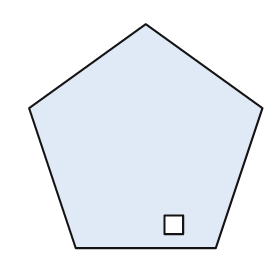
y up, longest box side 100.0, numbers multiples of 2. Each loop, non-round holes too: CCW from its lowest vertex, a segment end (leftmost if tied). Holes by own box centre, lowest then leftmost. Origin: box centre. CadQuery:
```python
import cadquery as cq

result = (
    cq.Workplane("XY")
    .moveTo(-30.0, -48.0)
    .lineTo(30.0, -48.0)
    .lineTo(50.0, 12.0)
    .lineTo(0.0, 48.0)
    .lineTo(-50.0, 12.0)
    .close()
    .moveTo(8.0, -42.0)
    .lineTo(16.0, -42.0)
    .lineTo(16.0, -34.0)
    .lineTo(8.0, -34.0)
    .close()
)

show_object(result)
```